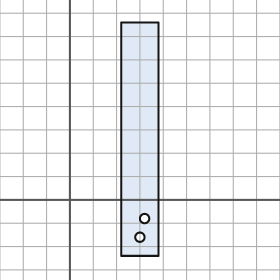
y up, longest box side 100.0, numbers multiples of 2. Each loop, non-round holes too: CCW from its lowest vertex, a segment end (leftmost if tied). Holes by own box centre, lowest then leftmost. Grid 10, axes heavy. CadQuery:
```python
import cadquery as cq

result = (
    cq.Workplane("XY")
    .moveTo(22.0, -24.0)
    .lineTo(38.0, -24.0)
    .lineTo(38.0, 76.0)
    .lineTo(22.0, 76.0)
    .close()
    .moveTo(30.0, -16.0)
    .circle(2.0)
    .moveTo(32.0, -8.0)
    .circle(2.0)
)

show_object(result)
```